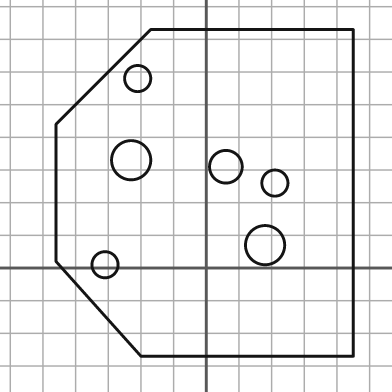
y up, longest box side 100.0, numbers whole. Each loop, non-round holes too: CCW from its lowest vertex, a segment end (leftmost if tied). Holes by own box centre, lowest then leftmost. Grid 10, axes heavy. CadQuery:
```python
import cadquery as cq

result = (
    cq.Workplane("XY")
    .moveTo(-20.0, -27.0)
    .lineTo(45.0, -27.0)
    .lineTo(45.0, 73.0)
    .lineTo(-17.0, 73.0)
    .lineTo(-46.0, 44.0)
    .lineTo(-46.0, 2.0)
    .close()
    .moveTo(-31.0, 1.0)
    .circle(4.0)
    .moveTo(18.0, 7.0)
    .circle(6.0)
    .moveTo(21.0, 26.0)
    .circle(4.0)
    .moveTo(6.0, 31.0)
    .circle(5.0)
    .moveTo(-23.0, 33.0)
    .circle(6.0)
    .moveTo(-21.0, 58.0)
    .circle(4.0)
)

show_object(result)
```